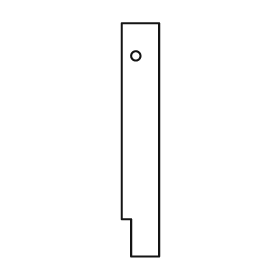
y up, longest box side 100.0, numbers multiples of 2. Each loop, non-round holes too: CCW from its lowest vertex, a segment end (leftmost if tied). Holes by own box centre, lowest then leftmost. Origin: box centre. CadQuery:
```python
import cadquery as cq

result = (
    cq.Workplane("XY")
    .moveTo(-4.0, -50.0)
    .lineTo(8.0, -50.0)
    .lineTo(8.0, 50.0)
    .lineTo(-8.0, 50.0)
    .lineTo(-8.0, -34.0)
    .lineTo(-4.0, -34.0)
    .close()
    .moveTo(-2.0, 36.0)
    .circle(2.0)
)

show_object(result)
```